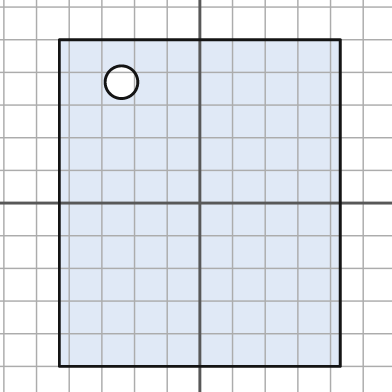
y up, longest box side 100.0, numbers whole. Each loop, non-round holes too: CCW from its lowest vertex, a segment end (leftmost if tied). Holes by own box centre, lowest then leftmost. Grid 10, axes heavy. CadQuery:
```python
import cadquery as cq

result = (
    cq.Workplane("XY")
    .moveTo(-43.0, -50.0)
    .lineTo(43.0, -50.0)
    .lineTo(43.0, 50.0)
    .lineTo(-43.0, 50.0)
    .close()
    .moveTo(-24.0, 37.0)
    .circle(5.0)
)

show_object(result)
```